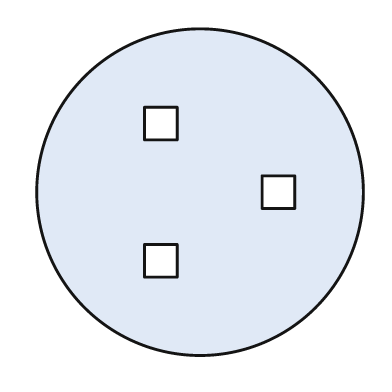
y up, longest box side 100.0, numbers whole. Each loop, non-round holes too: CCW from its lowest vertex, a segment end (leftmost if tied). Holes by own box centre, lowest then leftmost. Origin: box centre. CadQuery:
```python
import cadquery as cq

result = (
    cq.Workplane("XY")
    .moveTo(0.0, 0.0)
    .circle(50.0)
    .moveTo(-17.0, -26.0)
    .lineTo(-7.0, -26.0)
    .lineTo(-7.0, -16.0)
    .lineTo(-17.0, -16.0)
    .close()
    .moveTo(19.0, -5.0)
    .lineTo(29.0, -5.0)
    .lineTo(29.0, 5.0)
    .lineTo(19.0, 5.0)
    .close()
    .moveTo(-17.0, 16.0)
    .lineTo(-7.0, 16.0)
    .lineTo(-7.0, 26.0)
    .lineTo(-17.0, 26.0)
    .close()
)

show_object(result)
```